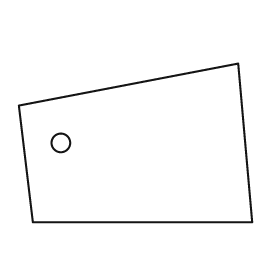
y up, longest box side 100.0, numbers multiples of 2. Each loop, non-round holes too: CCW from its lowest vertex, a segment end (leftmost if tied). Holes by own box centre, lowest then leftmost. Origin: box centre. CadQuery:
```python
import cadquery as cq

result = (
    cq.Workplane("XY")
    .moveTo(-44.0, -34.0)
    .lineTo(50.0, -34.0)
    .lineTo(44.0, 34.0)
    .lineTo(-50.0, 16.0)
    .close()
    .moveTo(-32.0, 0.0)
    .circle(4.0)
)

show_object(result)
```